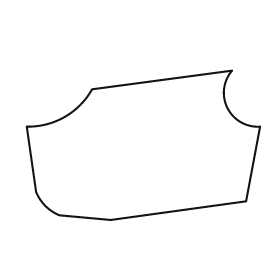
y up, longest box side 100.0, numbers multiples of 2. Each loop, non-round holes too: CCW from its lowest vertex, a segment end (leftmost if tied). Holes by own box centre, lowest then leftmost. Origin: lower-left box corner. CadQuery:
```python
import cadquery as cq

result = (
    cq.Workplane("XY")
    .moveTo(36.0, 0.0)
    .lineTo(94.0, 8.0)
    .lineTo(100.0, 40.0)
    .threePointArc((86.0, 48.0), (88.0, 64.0))
    .lineTo(28.0, 56.0)
    .threePointArc((16.0, 44.0), (0.0, 40.0))
    .lineTo(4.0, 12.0)
    .threePointArc((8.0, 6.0), (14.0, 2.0))
    .close()
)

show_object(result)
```